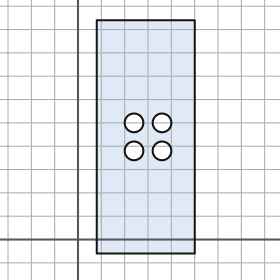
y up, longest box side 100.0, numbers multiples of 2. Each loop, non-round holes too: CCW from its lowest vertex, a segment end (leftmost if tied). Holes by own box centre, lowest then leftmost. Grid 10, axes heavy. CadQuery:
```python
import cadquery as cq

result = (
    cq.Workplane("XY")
    .moveTo(8.0, -6.0)
    .lineTo(50.0, -6.0)
    .lineTo(50.0, 94.0)
    .lineTo(8.0, 94.0)
    .close()
    .moveTo(24.0, 38.0)
    .circle(4.0)
    .moveTo(36.0, 38.0)
    .circle(4.0)
    .moveTo(24.0, 50.0)
    .circle(4.0)
    .moveTo(36.0, 50.0)
    .circle(4.0)
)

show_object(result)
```